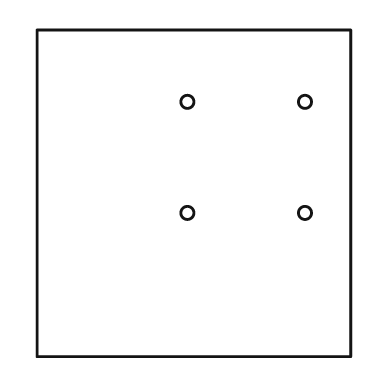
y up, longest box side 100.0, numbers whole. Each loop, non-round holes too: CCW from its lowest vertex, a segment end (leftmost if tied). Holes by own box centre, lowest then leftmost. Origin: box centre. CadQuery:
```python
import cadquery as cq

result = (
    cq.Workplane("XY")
    .moveTo(-48.0, -50.0)
    .lineTo(48.0, -50.0)
    .lineTo(48.0, 50.0)
    .lineTo(-48.0, 50.0)
    .close()
    .moveTo(-2.0, -6.0)
    .circle(2.0)
    .moveTo(34.0, -6.0)
    .circle(2.0)
    .moveTo(-2.0, 28.0)
    .circle(2.0)
    .moveTo(34.0, 28.0)
    .circle(2.0)
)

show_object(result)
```